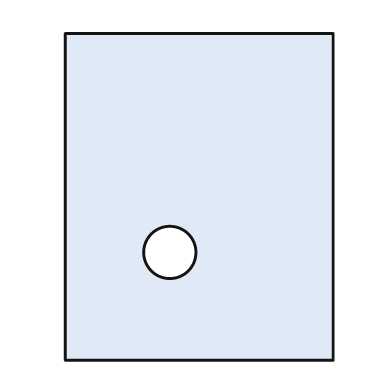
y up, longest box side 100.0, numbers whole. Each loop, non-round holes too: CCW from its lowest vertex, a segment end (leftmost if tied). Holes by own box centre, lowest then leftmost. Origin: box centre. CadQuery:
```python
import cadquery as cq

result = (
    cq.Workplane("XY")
    .moveTo(-41.0, -50.0)
    .lineTo(41.0, -50.0)
    .lineTo(41.0, 50.0)
    .lineTo(-41.0, 50.0)
    .close()
    .moveTo(-9.0, -17.0)
    .circle(8.0)
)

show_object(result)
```